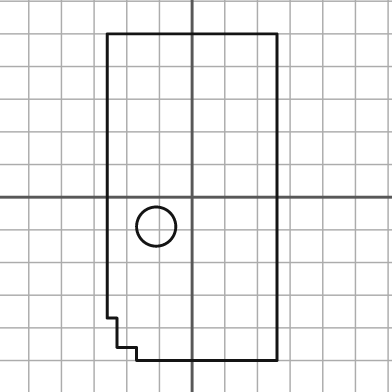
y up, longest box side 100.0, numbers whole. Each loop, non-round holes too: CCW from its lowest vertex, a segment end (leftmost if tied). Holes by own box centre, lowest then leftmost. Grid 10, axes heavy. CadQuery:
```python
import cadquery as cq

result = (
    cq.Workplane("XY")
    .moveTo(-17.0, -50.0)
    .lineTo(26.0, -50.0)
    .lineTo(26.0, 50.0)
    .lineTo(-26.0, 50.0)
    .lineTo(-26.0, -37.0)
    .lineTo(-23.0, -37.0)
    .lineTo(-23.0, -46.0)
    .lineTo(-17.0, -46.0)
    .close()
    .moveTo(-11.0, -9.0)
    .circle(6.0)
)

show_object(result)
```